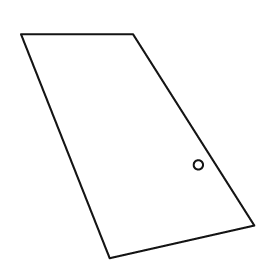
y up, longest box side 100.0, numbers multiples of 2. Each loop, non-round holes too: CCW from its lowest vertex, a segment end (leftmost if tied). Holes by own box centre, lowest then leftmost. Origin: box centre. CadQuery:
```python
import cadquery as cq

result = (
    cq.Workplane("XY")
    .moveTo(-12.0, -48.0)
    .lineTo(50.0, -34.0)
    .lineTo(-2.0, 48.0)
    .lineTo(-50.0, 48.0)
    .close()
    .moveTo(26.0, -8.0)
    .circle(2.0)
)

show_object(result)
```